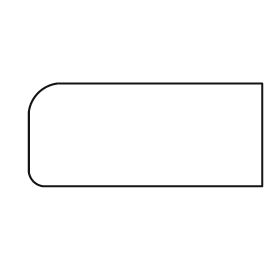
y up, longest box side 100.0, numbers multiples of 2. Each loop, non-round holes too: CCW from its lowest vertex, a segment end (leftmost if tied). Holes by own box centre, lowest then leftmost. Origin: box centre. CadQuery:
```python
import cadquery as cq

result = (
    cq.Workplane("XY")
    .moveTo(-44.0, -22.0)
    .lineTo(50.0, -22.0)
    .lineTo(50.0, 22.0)
    .lineTo(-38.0, 22.0)
    .threePointArc((-46.0, 18.0), (-50.0, 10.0))
    .lineTo(-50.0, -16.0)
    .threePointArc((-48.0, -20.0), (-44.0, -22.0))
    .close()
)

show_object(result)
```